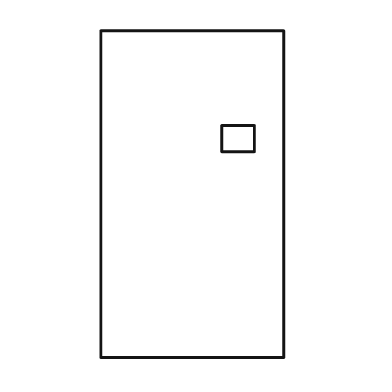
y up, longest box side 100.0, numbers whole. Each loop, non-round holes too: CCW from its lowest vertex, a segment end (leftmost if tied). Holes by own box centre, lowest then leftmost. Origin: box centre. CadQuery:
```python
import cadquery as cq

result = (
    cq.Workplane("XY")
    .moveTo(-28.0, -50.0)
    .lineTo(28.0, -50.0)
    .lineTo(28.0, 50.0)
    .lineTo(-28.0, 50.0)
    .close()
    .moveTo(9.0, 13.0)
    .lineTo(19.0, 13.0)
    .lineTo(19.0, 21.0)
    .lineTo(9.0, 21.0)
    .close()
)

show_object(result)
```